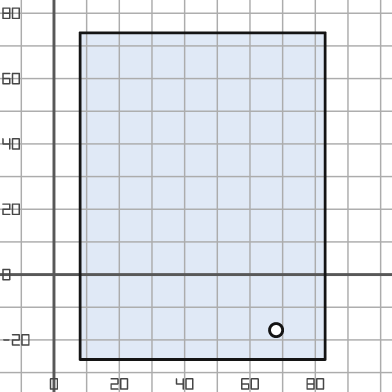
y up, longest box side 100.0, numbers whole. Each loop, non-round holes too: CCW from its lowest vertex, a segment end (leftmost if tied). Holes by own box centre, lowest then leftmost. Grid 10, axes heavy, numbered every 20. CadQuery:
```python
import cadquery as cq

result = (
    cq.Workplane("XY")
    .moveTo(8.0, -26.0)
    .lineTo(83.0, -26.0)
    .lineTo(83.0, 74.0)
    .lineTo(8.0, 74.0)
    .close()
    .moveTo(68.0, -17.0)
    .circle(2.0)
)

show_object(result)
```